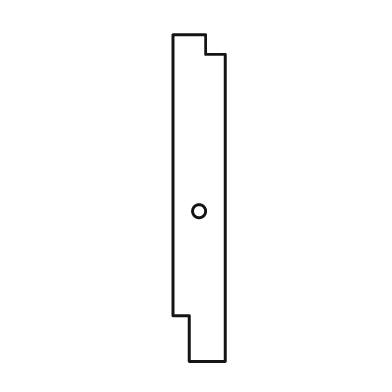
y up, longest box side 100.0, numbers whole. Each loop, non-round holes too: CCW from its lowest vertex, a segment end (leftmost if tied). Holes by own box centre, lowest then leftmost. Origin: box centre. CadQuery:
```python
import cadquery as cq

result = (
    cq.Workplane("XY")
    .moveTo(-3.0, -50.0)
    .lineTo(8.0, -50.0)
    .lineTo(8.0, 44.0)
    .lineTo(2.0, 44.0)
    .lineTo(2.0, 50.0)
    .lineTo(-8.0, 50.0)
    .lineTo(-8.0, -36.0)
    .lineTo(-3.0, -36.0)
    .close()
    .moveTo(0.0, -4.0)
    .circle(2.0)
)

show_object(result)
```